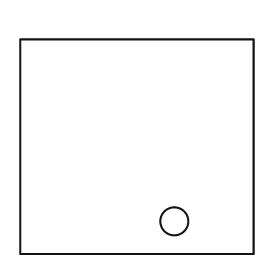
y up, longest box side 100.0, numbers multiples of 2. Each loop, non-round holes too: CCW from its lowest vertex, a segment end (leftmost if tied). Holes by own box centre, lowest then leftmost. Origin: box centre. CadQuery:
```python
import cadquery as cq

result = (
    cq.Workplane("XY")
    .moveTo(-50.0, -46.0)
    .lineTo(50.0, -46.0)
    .lineTo(50.0, 46.0)
    .lineTo(-50.0, 46.0)
    .close()
    .moveTo(16.0, -32.0)
    .circle(6.0)
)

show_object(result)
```